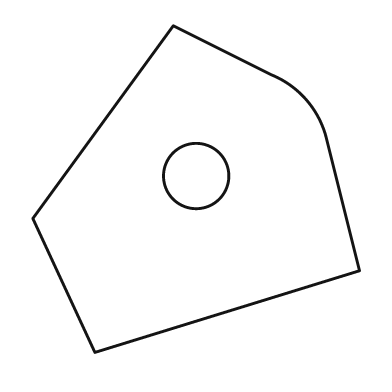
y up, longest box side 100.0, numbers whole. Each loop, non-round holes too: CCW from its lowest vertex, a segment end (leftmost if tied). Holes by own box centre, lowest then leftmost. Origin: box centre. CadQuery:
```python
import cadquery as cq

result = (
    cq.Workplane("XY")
    .moveTo(-31.0, -50.0)
    .lineTo(50.0, -25.0)
    .lineTo(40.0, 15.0)
    .threePointArc((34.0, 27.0), (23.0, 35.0))
    .lineTo(-7.0, 50.0)
    .lineTo(-50.0, -9.0)
    .close()
    .moveTo(0.0, 4.0)
    .circle(10.0)
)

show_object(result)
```